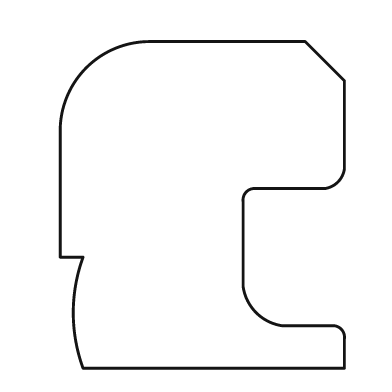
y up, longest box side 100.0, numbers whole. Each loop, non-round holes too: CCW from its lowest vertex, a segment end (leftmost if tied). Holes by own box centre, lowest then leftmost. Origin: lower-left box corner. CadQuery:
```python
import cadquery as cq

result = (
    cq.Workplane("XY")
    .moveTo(7.0, 0.0)
    .lineTo(87.0, 0.0)
    .lineTo(87.0, 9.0)
    .threePointArc((86.0, 12.0), (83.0, 13.0))
    .lineTo(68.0, 13.0)
    .threePointArc((60.0, 17.0), (56.0, 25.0))
    .lineTo(56.0, 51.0)
    .threePointArc((57.0, 54.0), (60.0, 55.0))
    .lineTo(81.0, 55.0)
    .threePointArc((85.0, 57.0), (87.0, 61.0))
    .lineTo(87.0, 88.0)
    .lineTo(75.0, 100.0)
    .lineTo(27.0, 100.0)
    .threePointArc((8.0, 92.0), (0.0, 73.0))
    .lineTo(0.0, 34.0)
    .lineTo(7.0, 34.0)
    .threePointArc((4.0, 17.0), (7.0, 0.0))
    .close()
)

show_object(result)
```